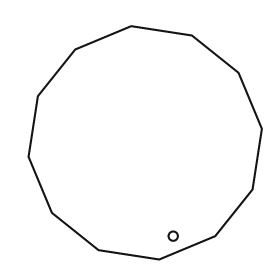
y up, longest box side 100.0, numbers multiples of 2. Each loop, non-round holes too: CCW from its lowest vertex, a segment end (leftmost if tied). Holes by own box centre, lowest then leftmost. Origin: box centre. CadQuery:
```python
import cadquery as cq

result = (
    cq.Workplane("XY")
    .moveTo(6.0, -50.0)
    .lineTo(30.0, -40.0)
    .lineTo(46.0, -20.0)
    .lineTo(50.0, 6.0)
    .lineTo(40.0, 30.0)
    .lineTo(20.0, 46.0)
    .lineTo(-6.0, 50.0)
    .lineTo(-30.0, 40.0)
    .lineTo(-46.0, 20.0)
    .lineTo(-50.0, -6.0)
    .lineTo(-40.0, -30.0)
    .lineTo(-20.0, -46.0)
    .close()
    .moveTo(12.0, -40.0)
    .circle(2.0)
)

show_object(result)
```